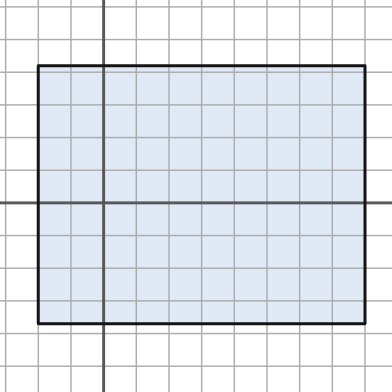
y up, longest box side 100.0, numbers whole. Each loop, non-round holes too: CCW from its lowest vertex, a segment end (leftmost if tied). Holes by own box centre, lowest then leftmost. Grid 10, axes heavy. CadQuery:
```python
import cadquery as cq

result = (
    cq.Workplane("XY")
    .moveTo(-20.0, -37.0)
    .lineTo(80.0, -37.0)
    .lineTo(80.0, 42.0)
    .lineTo(-20.0, 42.0)
    .close()
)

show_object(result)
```